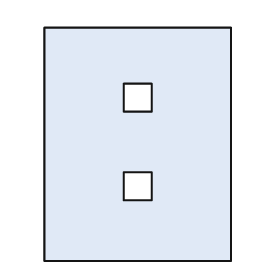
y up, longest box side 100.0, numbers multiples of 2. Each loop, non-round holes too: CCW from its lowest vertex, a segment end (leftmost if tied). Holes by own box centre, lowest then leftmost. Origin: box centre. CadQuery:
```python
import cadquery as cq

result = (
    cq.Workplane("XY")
    .moveTo(-40.0, -50.0)
    .lineTo(40.0, -50.0)
    .lineTo(40.0, 50.0)
    .lineTo(-40.0, 50.0)
    .close()
    .moveTo(-6.0, -24.0)
    .lineTo(6.0, -24.0)
    .lineTo(6.0, -12.0)
    .lineTo(-6.0, -12.0)
    .close()
    .moveTo(-6.0, 14.0)
    .lineTo(6.0, 14.0)
    .lineTo(6.0, 26.0)
    .lineTo(-6.0, 26.0)
    .close()
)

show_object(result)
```